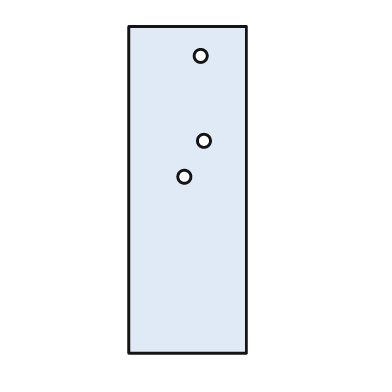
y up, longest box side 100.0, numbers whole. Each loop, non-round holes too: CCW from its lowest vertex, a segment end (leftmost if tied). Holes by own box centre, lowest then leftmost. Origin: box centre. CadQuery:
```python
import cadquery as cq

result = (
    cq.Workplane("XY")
    .moveTo(-18.0, -50.0)
    .lineTo(18.0, -50.0)
    .lineTo(18.0, 50.0)
    .lineTo(-18.0, 50.0)
    .close()
    .moveTo(-1.0, 4.0)
    .circle(2.0)
    .moveTo(5.0, 15.0)
    .circle(2.0)
    .moveTo(4.0, 41.0)
    .circle(2.0)
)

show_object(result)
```